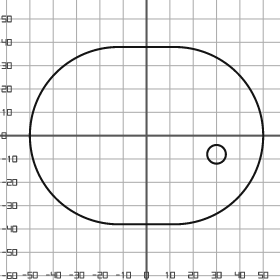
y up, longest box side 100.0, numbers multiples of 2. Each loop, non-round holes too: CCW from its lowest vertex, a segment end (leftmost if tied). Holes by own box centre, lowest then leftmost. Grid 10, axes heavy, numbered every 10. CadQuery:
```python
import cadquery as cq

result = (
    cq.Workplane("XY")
    .moveTo(-12.0, -38.0)
    .lineTo(12.0, -38.0)
    .threePointArc((50.0, 0.0), (12.0, 38.0))
    .lineTo(-12.0, 38.0)
    .threePointArc((-50.0, 0.0), (-12.0, -38.0))
    .close()
    .moveTo(30.0, -8.0)
    .circle(4.0)
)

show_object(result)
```